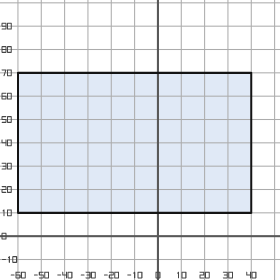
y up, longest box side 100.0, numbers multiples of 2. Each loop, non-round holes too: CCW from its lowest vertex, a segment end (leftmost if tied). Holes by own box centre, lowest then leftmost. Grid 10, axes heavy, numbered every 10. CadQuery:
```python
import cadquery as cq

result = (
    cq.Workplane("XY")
    .moveTo(-60.0, 10.0)
    .lineTo(40.0, 10.0)
    .lineTo(40.0, 70.0)
    .lineTo(-60.0, 70.0)
    .close()
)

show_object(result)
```